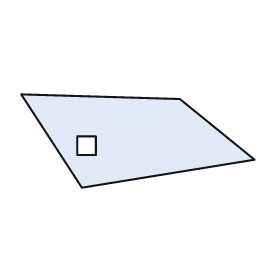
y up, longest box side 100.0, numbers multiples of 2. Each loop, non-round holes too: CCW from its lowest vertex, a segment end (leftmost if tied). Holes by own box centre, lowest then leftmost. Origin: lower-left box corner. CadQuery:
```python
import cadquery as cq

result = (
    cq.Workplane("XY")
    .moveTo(26.0, 0.0)
    .lineTo(100.0, 12.0)
    .lineTo(68.0, 38.0)
    .lineTo(0.0, 40.0)
    .close()
    .moveTo(24.0, 14.0)
    .lineTo(32.0, 14.0)
    .lineTo(32.0, 22.0)
    .lineTo(24.0, 22.0)
    .close()
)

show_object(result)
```